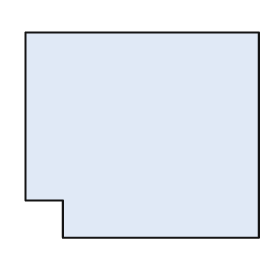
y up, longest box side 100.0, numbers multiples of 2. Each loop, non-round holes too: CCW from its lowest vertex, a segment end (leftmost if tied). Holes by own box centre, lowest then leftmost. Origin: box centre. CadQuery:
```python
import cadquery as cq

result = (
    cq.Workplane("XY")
    .moveTo(-34.0, -44.0)
    .lineTo(50.0, -44.0)
    .lineTo(50.0, 44.0)
    .lineTo(-50.0, 44.0)
    .lineTo(-50.0, -28.0)
    .lineTo(-34.0, -28.0)
    .close()
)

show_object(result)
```